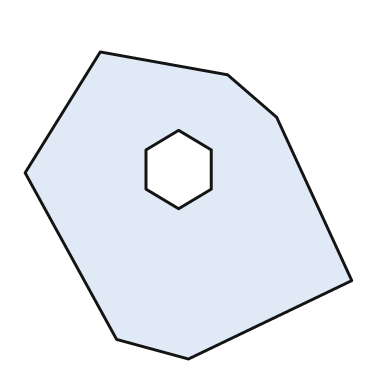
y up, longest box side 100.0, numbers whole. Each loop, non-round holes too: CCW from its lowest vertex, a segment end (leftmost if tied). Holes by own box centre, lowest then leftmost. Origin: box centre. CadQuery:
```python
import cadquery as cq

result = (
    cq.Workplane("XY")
    .moveTo(0.0, -47.0)
    .lineTo(50.0, -23.0)
    .lineTo(27.0, 27.0)
    .lineTo(12.0, 40.0)
    .lineTo(-27.0, 47.0)
    .lineTo(-50.0, 10.0)
    .lineTo(-22.0, -41.0)
    .close()
    .moveTo(-3.0, -1.0)
    .lineTo(7.0, 5.0)
    .lineTo(7.0, 17.0)
    .lineTo(-3.0, 23.0)
    .lineTo(-13.0, 17.0)
    .lineTo(-13.0, 5.0)
    .close()
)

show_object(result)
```